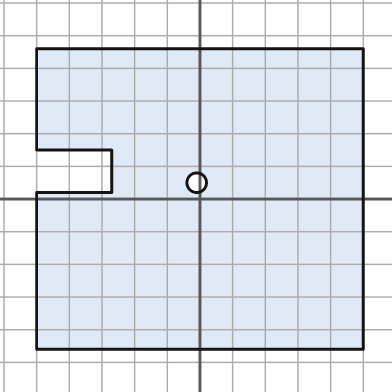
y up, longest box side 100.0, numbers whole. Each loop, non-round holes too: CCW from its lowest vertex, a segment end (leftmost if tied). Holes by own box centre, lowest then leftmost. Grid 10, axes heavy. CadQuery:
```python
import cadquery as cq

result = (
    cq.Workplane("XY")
    .moveTo(-50.0, -46.0)
    .lineTo(50.0, -46.0)
    .lineTo(50.0, 46.0)
    .lineTo(-50.0, 46.0)
    .lineTo(-50.0, 15.0)
    .lineTo(-27.0, 15.0)
    .lineTo(-27.0, 2.0)
    .lineTo(-50.0, 2.0)
    .close()
    .moveTo(-1.0, 5.0)
    .circle(3.0)
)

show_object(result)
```